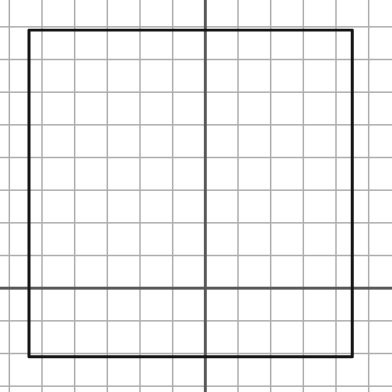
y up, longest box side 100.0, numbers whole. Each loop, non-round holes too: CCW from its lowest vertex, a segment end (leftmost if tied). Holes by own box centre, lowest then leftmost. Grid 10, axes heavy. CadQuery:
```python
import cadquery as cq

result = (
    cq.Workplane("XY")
    .moveTo(-54.0, -21.0)
    .lineTo(45.0, -21.0)
    .lineTo(45.0, 79.0)
    .lineTo(-54.0, 79.0)
    .close()
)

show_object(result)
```